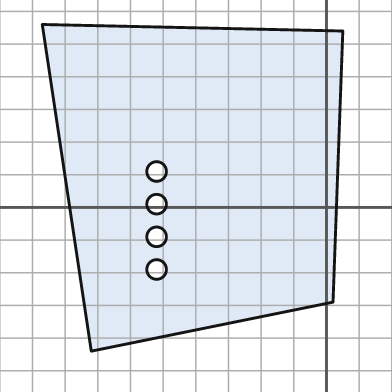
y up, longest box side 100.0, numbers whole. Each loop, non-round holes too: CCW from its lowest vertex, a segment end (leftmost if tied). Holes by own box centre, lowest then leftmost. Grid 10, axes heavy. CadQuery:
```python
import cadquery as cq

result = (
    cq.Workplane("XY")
    .moveTo(-72.0, -44.0)
    .lineTo(2.0, -29.0)
    .lineTo(5.0, 54.0)
    .lineTo(-87.0, 56.0)
    .close()
    .moveTo(-52.0, -19.0)
    .circle(3.0)
    .moveTo(-52.0, -9.0)
    .circle(3.0)
    .moveTo(-52.0, 1.0)
    .circle(3.0)
    .moveTo(-52.0, 11.0)
    .circle(3.0)
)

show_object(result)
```